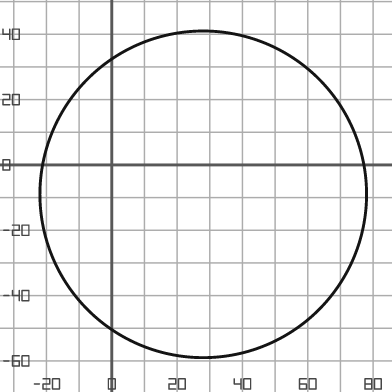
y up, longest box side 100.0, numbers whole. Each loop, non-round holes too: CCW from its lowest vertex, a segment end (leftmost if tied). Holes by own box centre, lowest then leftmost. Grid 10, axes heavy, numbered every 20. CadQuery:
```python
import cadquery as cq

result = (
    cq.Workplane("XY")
    .moveTo(28.0, -9.0)
    .circle(50.0)
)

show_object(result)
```